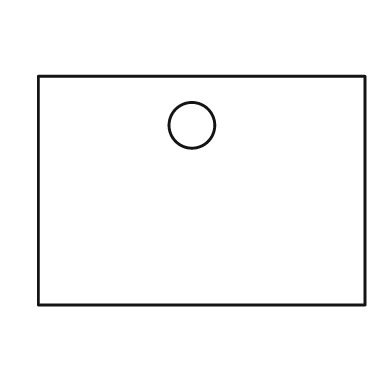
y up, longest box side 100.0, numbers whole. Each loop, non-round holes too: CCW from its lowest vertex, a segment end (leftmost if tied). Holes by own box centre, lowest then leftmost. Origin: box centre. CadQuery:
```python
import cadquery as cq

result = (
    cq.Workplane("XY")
    .moveTo(-50.0, -35.0)
    .lineTo(50.0, -35.0)
    .lineTo(50.0, 35.0)
    .lineTo(-50.0, 35.0)
    .close()
    .moveTo(-3.0, 20.0)
    .circle(7.0)
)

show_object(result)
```